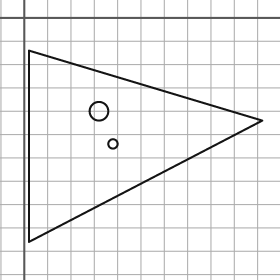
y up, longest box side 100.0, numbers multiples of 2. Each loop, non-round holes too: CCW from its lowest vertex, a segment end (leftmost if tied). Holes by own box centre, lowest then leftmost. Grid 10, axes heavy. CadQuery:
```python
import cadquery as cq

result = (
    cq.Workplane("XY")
    .moveTo(2.0, -96.0)
    .lineTo(102.0, -44.0)
    .lineTo(2.0, -14.0)
    .close()
    .moveTo(38.0, -54.0)
    .circle(2.0)
    .moveTo(32.0, -40.0)
    .circle(4.0)
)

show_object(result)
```